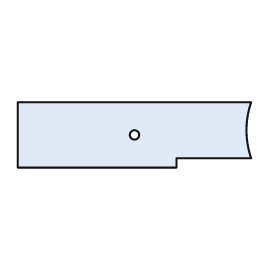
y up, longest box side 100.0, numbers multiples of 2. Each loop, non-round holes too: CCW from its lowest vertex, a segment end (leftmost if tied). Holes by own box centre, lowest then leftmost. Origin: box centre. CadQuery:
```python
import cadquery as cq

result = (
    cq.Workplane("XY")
    .moveTo(-50.0, -14.0)
    .lineTo(18.0, -14.0)
    .lineTo(18.0, -10.0)
    .lineTo(50.0, -10.0)
    .threePointArc((48.0, 2.0), (50.0, 14.0))
    .lineTo(-50.0, 14.0)
    .close()
    .moveTo(0.0, 0.0)
    .circle(2.0)
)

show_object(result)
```